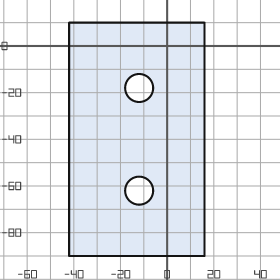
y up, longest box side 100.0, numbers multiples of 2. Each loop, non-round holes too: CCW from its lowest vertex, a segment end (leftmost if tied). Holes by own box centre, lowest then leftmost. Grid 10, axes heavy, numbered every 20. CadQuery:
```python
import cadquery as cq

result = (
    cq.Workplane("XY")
    .moveTo(-42.0, -90.0)
    .lineTo(16.0, -90.0)
    .lineTo(16.0, 10.0)
    .lineTo(-42.0, 10.0)
    .close()
    .moveTo(-12.0, -62.0)
    .circle(6.0)
    .moveTo(-12.0, -18.0)
    .circle(6.0)
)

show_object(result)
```